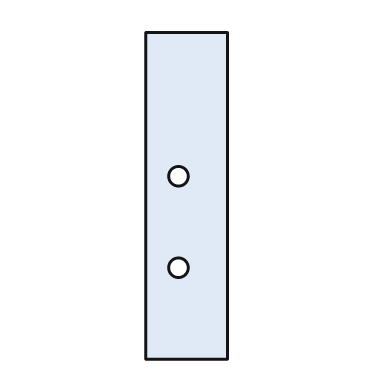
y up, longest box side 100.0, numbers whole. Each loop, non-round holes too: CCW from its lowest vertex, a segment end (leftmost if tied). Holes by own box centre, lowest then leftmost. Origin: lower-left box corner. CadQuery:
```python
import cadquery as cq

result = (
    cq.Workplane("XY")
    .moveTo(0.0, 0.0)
    .lineTo(25.0, 0.0)
    .lineTo(25.0, 100.0)
    .lineTo(0.0, 100.0)
    .close()
    .moveTo(10.0, 28.0)
    .circle(3.0)
    .moveTo(10.0, 56.0)
    .circle(3.0)
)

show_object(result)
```